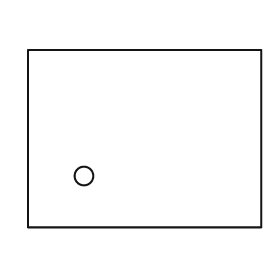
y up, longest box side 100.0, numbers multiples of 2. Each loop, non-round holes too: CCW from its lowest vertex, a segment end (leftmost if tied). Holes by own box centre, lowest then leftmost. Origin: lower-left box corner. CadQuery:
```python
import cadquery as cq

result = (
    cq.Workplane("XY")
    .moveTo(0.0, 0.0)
    .lineTo(100.0, 0.0)
    .lineTo(100.0, 76.0)
    .lineTo(0.0, 76.0)
    .close()
    .moveTo(24.0, 22.0)
    .circle(4.0)
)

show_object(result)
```